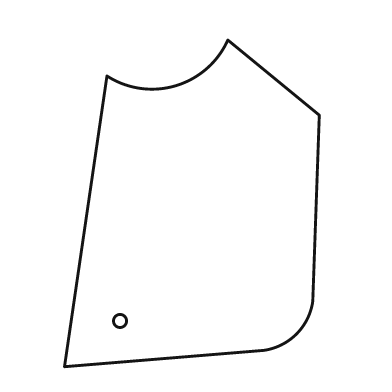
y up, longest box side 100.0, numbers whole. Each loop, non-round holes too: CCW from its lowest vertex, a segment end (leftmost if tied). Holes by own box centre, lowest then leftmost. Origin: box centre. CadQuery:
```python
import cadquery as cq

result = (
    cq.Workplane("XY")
    .moveTo(-39.0, -50.0)
    .lineTo(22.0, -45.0)
    .threePointArc((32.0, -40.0), (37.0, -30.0))
    .lineTo(39.0, 27.0)
    .lineTo(11.0, 50.0)
    .threePointArc((-5.0, 36.0), (-26.0, 39.0))
    .close()
    .moveTo(-22.0, -36.0)
    .circle(2.0)
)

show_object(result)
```